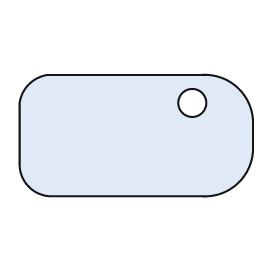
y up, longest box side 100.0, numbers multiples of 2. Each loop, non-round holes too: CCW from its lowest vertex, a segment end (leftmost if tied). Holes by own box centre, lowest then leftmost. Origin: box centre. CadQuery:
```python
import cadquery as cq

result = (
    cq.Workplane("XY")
    .moveTo(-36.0, -26.0)
    .lineTo(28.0, -26.0)
    .threePointArc((44.0, -20.0), (50.0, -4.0))
    .lineTo(50.0, 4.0)
    .threePointArc((44.0, 20.0), (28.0, 26.0))
    .lineTo(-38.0, 26.0)
    .threePointArc((-46.0, 22.0), (-50.0, 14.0))
    .lineTo(-50.0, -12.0)
    .threePointArc((-46.0, -22.0), (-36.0, -26.0))
    .close()
    .moveTo(24.0, 14.0)
    .circle(6.0)
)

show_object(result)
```